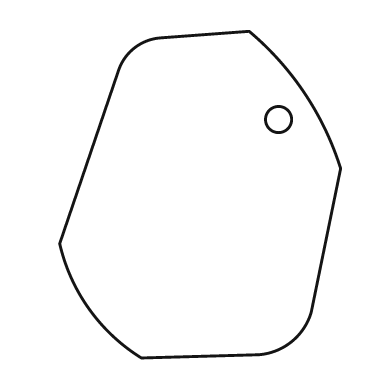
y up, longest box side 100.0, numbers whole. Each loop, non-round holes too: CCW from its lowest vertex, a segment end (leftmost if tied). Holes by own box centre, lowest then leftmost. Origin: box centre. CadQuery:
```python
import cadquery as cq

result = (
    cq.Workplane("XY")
    .moveTo(-18.0, -50.0)
    .lineTo(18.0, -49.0)
    .threePointArc((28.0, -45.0), (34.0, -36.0))
    .lineTo(43.0, 8.0)
    .threePointArc((32.0, 31.0), (15.0, 50.0))
    .lineTo(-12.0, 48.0)
    .threePointArc((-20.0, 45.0), (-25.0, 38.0))
    .lineTo(-43.0, -15.0)
    .threePointArc((-34.0, -35.0), (-18.0, -50.0))
    .close()
    .moveTo(24.0, 23.0)
    .circle(4.0)
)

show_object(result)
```